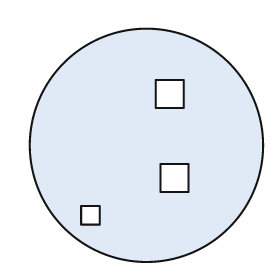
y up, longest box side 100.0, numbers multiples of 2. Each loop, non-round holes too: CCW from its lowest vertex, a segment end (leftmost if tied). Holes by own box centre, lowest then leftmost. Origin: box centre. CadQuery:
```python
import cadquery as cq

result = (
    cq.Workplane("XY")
    .moveTo(0.0, 0.0)
    .circle(50.0)
    .moveTo(-28.0, -34.0)
    .lineTo(-20.0, -34.0)
    .lineTo(-20.0, -26.0)
    .lineTo(-28.0, -26.0)
    .close()
    .moveTo(6.0, -20.0)
    .lineTo(18.0, -20.0)
    .lineTo(18.0, -8.0)
    .lineTo(6.0, -8.0)
    .close()
    .moveTo(4.0, 16.0)
    .lineTo(16.0, 16.0)
    .lineTo(16.0, 28.0)
    .lineTo(4.0, 28.0)
    .close()
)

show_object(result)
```